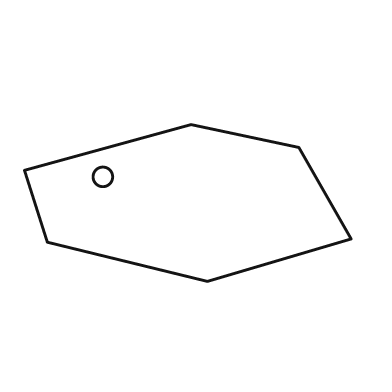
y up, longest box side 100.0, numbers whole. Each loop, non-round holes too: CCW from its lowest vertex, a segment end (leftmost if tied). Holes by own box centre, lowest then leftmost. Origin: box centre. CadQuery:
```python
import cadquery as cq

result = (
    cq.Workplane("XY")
    .moveTo(6.0, -24.0)
    .lineTo(50.0, -11.0)
    .lineTo(34.0, 17.0)
    .lineTo(1.0, 24.0)
    .lineTo(-50.0, 10.0)
    .lineTo(-43.0, -12.0)
    .close()
    .moveTo(-26.0, 8.0)
    .circle(3.0)
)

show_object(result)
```